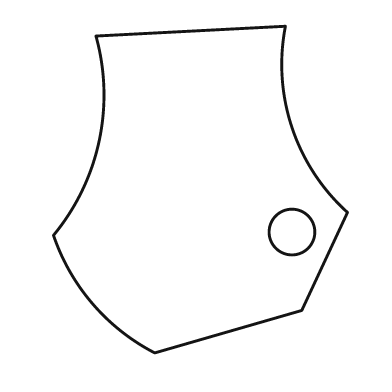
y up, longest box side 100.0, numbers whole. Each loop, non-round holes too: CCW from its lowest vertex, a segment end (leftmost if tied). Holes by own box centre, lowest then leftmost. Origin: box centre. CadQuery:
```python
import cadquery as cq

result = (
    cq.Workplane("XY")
    .moveTo(-14.0, -50.0)
    .lineTo(31.0, -37.0)
    .lineTo(45.0, -7.0)
    .threePointArc((28.0, 19.0), (26.0, 50.0))
    .lineTo(-32.0, 47.0)
    .threePointArc((-31.0, 15.0), (-45.0, -14.0))
    .threePointArc((-33.0, -35.0), (-14.0, -50.0))
    .close()
    .moveTo(28.0, -13.0)
    .circle(7.0)
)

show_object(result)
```